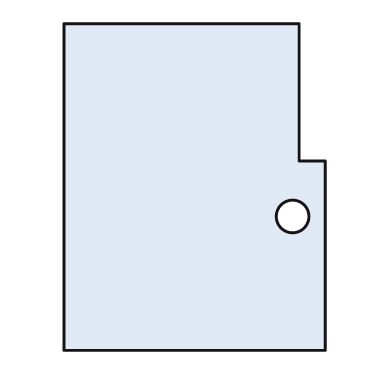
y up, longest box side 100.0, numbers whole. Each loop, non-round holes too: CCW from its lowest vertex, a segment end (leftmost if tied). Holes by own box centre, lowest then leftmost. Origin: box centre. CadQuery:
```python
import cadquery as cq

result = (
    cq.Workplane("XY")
    .moveTo(-40.0, -50.0)
    .lineTo(40.0, -50.0)
    .lineTo(40.0, 8.0)
    .lineTo(32.0, 8.0)
    .lineTo(32.0, 50.0)
    .lineTo(-40.0, 50.0)
    .close()
    .moveTo(30.0, -9.0)
    .circle(5.0)
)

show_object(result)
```